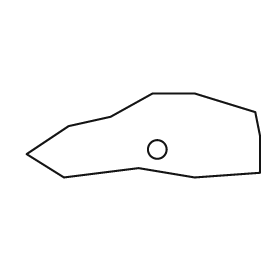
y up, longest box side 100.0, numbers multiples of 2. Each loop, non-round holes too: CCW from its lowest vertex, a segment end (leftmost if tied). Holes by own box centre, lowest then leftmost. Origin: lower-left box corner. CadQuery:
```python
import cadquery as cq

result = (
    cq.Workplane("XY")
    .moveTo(16.0, 0.0)
    .lineTo(48.0, 4.0)
    .lineTo(72.0, 0.0)
    .lineTo(100.0, 2.0)
    .lineTo(100.0, 18.0)
    .lineTo(98.0, 28.0)
    .lineTo(72.0, 36.0)
    .lineTo(54.0, 36.0)
    .lineTo(36.0, 26.0)
    .lineTo(18.0, 22.0)
    .lineTo(0.0, 10.0)
    .close()
    .moveTo(56.0, 12.0)
    .circle(4.0)
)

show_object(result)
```